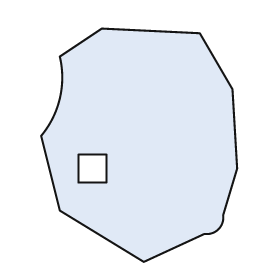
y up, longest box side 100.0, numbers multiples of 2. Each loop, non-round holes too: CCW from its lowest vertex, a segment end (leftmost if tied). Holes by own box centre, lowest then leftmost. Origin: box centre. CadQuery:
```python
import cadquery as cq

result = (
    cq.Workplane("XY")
    .moveTo(2.0, -50.0)
    .lineTo(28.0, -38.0)
    .threePointArc((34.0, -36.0), (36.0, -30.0))
    .lineTo(42.0, -10.0)
    .lineTo(40.0, 24.0)
    .lineTo(26.0, 48.0)
    .lineTo(-16.0, 50.0)
    .lineTo(-34.0, 38.0)
    .threePointArc((-34.0, 20.0), (-42.0, 4.0))
    .lineTo(-34.0, -28.0)
    .close()
    .moveTo(-26.0, -16.0)
    .lineTo(-14.0, -16.0)
    .lineTo(-14.0, -4.0)
    .lineTo(-26.0, -4.0)
    .close()
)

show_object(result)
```